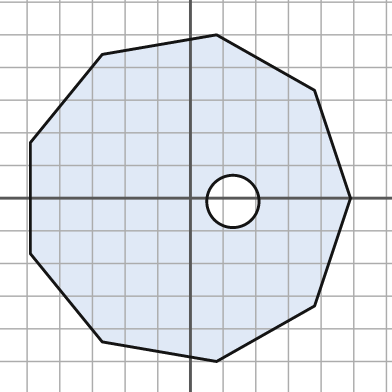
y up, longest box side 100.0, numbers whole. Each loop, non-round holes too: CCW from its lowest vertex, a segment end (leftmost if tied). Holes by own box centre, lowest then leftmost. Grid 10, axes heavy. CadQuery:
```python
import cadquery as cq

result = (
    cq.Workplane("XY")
    .moveTo(8.0, -50.0)
    .lineTo(38.0, -33.0)
    .lineTo(49.0, 0.0)
    .lineTo(38.0, 33.0)
    .lineTo(8.0, 50.0)
    .lineTo(-27.0, 44.0)
    .lineTo(-49.0, 17.0)
    .lineTo(-49.0, -17.0)
    .lineTo(-27.0, -44.0)
    .close()
    .moveTo(13.0, -1.0)
    .circle(8.0)
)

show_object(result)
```